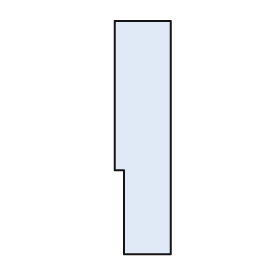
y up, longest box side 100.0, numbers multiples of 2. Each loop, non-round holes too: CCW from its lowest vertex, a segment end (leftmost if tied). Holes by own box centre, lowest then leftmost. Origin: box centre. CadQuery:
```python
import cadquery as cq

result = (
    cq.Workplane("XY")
    .moveTo(-8.0, -50.0)
    .lineTo(12.0, -50.0)
    .lineTo(12.0, 50.0)
    .lineTo(-12.0, 50.0)
    .lineTo(-12.0, -14.0)
    .lineTo(-8.0, -14.0)
    .close()
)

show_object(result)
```